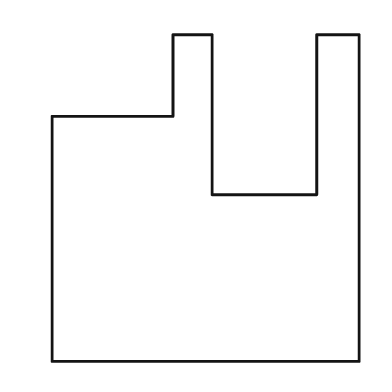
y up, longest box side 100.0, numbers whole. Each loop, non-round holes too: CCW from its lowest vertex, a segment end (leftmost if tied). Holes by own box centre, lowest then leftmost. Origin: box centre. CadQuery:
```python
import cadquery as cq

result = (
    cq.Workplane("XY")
    .moveTo(-47.0, -50.0)
    .lineTo(47.0, -50.0)
    .lineTo(47.0, 50.0)
    .lineTo(34.0, 50.0)
    .lineTo(34.0, 1.0)
    .lineTo(2.0, 1.0)
    .lineTo(2.0, 50.0)
    .lineTo(-10.0, 50.0)
    .lineTo(-10.0, 25.0)
    .lineTo(-47.0, 25.0)
    .close()
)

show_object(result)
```